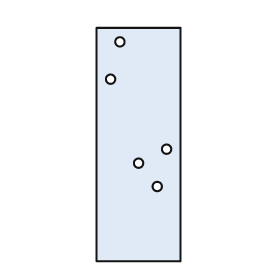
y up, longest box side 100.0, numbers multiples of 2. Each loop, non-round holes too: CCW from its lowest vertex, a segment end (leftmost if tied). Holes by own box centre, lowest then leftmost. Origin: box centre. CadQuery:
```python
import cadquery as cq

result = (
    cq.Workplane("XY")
    .moveTo(-18.0, -50.0)
    .lineTo(18.0, -50.0)
    .lineTo(18.0, 50.0)
    .lineTo(-18.0, 50.0)
    .close()
    .moveTo(8.0, -18.0)
    .circle(2.0)
    .moveTo(0.0, -8.0)
    .circle(2.0)
    .moveTo(12.0, -2.0)
    .circle(2.0)
    .moveTo(-12.0, 28.0)
    .circle(2.0)
    .moveTo(-8.0, 44.0)
    .circle(2.0)
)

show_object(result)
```